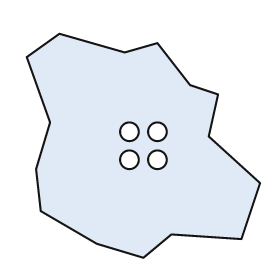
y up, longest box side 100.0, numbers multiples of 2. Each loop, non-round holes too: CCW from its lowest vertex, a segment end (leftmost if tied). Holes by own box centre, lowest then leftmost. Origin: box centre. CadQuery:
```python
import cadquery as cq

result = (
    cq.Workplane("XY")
    .moveTo(0.0, -48.0)
    .lineTo(12.0, -38.0)
    .lineTo(42.0, -40.0)
    .lineTo(50.0, -16.0)
    .lineTo(28.0, 4.0)
    .lineTo(32.0, 22.0)
    .lineTo(20.0, 26.0)
    .lineTo(6.0, 44.0)
    .lineTo(-8.0, 40.0)
    .lineTo(-36.0, 48.0)
    .lineTo(-50.0, 38.0)
    .lineTo(-40.0, 10.0)
    .lineTo(-46.0, -10.0)
    .lineTo(-44.0, -28.0)
    .lineTo(-20.0, -42.0)
    .close()
    .moveTo(-6.0, -6.0)
    .circle(4.0)
    .moveTo(6.0, -6.0)
    .circle(4.0)
    .moveTo(-6.0, 6.0)
    .circle(4.0)
    .moveTo(6.0, 6.0)
    .circle(4.0)
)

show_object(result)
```